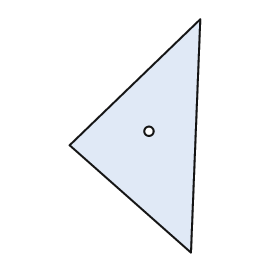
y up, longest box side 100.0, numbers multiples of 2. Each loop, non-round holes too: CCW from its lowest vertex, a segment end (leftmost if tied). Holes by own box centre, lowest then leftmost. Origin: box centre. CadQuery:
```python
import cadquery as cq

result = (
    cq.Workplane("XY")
    .moveTo(24.0, -50.0)
    .lineTo(28.0, 50.0)
    .lineTo(-28.0, -4.0)
    .close()
    .moveTo(6.0, 2.0)
    .circle(2.0)
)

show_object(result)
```